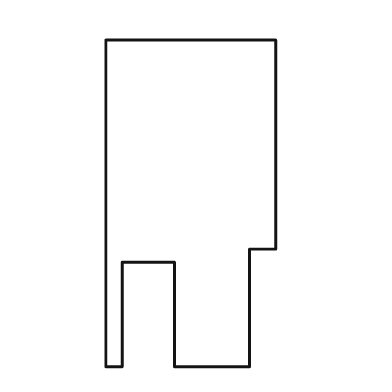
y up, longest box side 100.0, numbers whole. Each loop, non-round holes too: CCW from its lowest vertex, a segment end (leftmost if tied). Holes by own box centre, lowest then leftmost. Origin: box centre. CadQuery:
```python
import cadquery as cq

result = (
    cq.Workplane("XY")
    .moveTo(-26.0, -50.0)
    .lineTo(-21.0, -50.0)
    .lineTo(-21.0, -18.0)
    .lineTo(-5.0, -18.0)
    .lineTo(-5.0, -50.0)
    .lineTo(18.0, -50.0)
    .lineTo(18.0, -14.0)
    .lineTo(26.0, -14.0)
    .lineTo(26.0, 50.0)
    .lineTo(-26.0, 50.0)
    .close()
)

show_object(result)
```